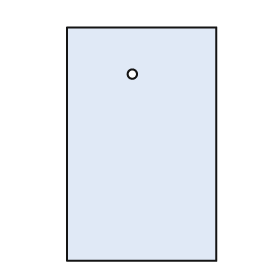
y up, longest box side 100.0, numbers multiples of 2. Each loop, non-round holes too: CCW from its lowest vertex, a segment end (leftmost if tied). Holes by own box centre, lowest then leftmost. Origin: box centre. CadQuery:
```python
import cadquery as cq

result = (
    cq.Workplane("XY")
    .moveTo(-32.0, -50.0)
    .lineTo(32.0, -50.0)
    .lineTo(32.0, 50.0)
    .lineTo(-32.0, 50.0)
    .close()
    .moveTo(-4.0, 30.0)
    .circle(2.0)
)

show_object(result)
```